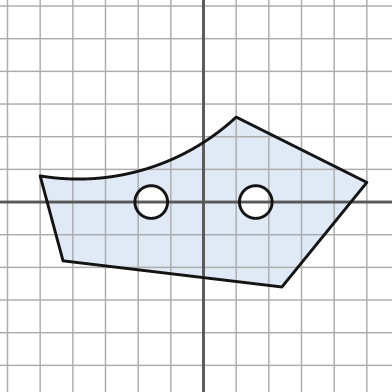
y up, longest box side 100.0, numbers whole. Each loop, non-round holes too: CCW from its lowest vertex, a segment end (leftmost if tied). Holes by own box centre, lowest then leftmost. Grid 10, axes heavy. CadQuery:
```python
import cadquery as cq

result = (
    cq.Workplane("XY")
    .moveTo(24.0, -26.0)
    .lineTo(50.0, 6.0)
    .lineTo(10.0, 26.0)
    .threePointArc((-18.0, 10.0), (-50.0, 8.0))
    .lineTo(-43.0, -18.0)
    .close()
    .moveTo(-16.0, 0.0)
    .circle(5.0)
    .moveTo(16.0, 0.0)
    .circle(5.0)
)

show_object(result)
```